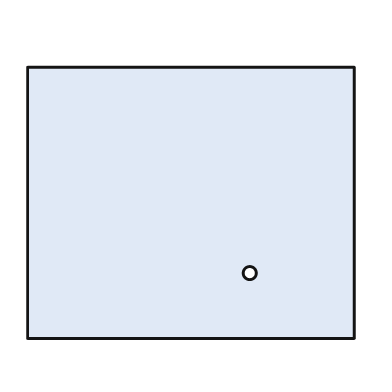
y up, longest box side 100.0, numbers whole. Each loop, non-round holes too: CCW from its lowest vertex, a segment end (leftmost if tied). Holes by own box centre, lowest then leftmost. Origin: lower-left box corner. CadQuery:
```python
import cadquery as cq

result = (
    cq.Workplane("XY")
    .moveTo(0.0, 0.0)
    .lineTo(100.0, 0.0)
    .lineTo(100.0, 83.0)
    .lineTo(0.0, 83.0)
    .close()
    .moveTo(68.0, 20.0)
    .circle(2.0)
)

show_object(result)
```